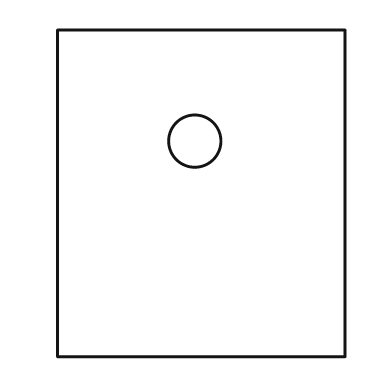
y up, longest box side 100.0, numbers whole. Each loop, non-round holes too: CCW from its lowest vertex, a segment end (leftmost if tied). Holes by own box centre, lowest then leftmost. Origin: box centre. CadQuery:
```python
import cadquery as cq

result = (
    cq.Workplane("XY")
    .moveTo(-44.0, -50.0)
    .lineTo(44.0, -50.0)
    .lineTo(44.0, 50.0)
    .lineTo(-44.0, 50.0)
    .close()
    .moveTo(-2.0, 16.0)
    .circle(8.0)
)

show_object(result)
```